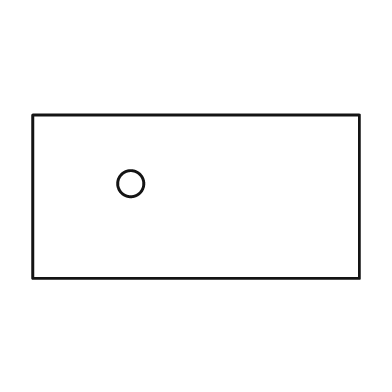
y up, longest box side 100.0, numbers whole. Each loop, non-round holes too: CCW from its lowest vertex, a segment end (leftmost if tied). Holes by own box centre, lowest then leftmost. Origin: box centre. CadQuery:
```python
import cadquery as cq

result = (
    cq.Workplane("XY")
    .moveTo(-50.0, -25.0)
    .lineTo(50.0, -25.0)
    .lineTo(50.0, 25.0)
    .lineTo(-50.0, 25.0)
    .close()
    .moveTo(-20.0, 4.0)
    .circle(4.0)
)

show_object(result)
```